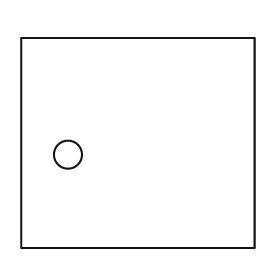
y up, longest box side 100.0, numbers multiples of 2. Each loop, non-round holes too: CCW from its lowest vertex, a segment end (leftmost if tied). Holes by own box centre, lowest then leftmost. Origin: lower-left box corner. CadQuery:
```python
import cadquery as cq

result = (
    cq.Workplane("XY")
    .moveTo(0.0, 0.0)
    .lineTo(100.0, 0.0)
    .lineTo(100.0, 90.0)
    .lineTo(0.0, 90.0)
    .close()
    .moveTo(20.0, 40.0)
    .circle(6.0)
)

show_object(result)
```